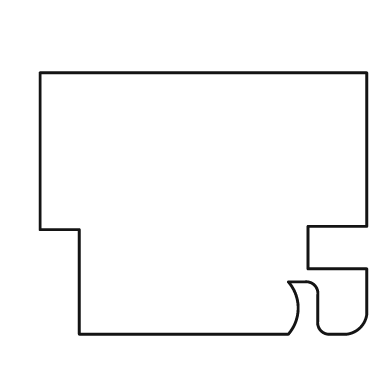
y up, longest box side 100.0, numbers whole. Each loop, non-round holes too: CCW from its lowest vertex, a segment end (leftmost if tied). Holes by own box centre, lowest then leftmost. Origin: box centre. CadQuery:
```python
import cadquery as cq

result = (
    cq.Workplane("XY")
    .moveTo(-38.0, -40.0)
    .lineTo(26.0, -40.0)
    .threePointArc((29.0, -32.0), (26.0, -24.0))
    .lineTo(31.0, -24.0)
    .threePointArc((34.0, -25.0), (35.0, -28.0))
    .lineTo(35.0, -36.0)
    .threePointArc((36.0, -39.0), (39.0, -40.0))
    .lineTo(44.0, -40.0)
    .threePointArc((48.0, -38.0), (50.0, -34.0))
    .lineTo(50.0, -20.0)
    .lineTo(32.0, -20.0)
    .lineTo(32.0, -7.0)
    .lineTo(50.0, -7.0)
    .lineTo(50.0, 40.0)
    .lineTo(-50.0, 40.0)
    .lineTo(-50.0, -8.0)
    .lineTo(-38.0, -8.0)
    .close()
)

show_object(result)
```